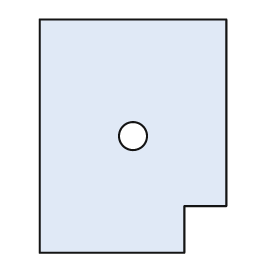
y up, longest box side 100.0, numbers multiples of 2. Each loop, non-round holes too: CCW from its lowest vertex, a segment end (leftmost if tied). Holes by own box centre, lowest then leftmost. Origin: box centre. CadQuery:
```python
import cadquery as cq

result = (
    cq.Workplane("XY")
    .moveTo(-40.0, -50.0)
    .lineTo(22.0, -50.0)
    .lineTo(22.0, -30.0)
    .lineTo(40.0, -30.0)
    .lineTo(40.0, 50.0)
    .lineTo(-40.0, 50.0)
    .close()
    .moveTo(0.0, 0.0)
    .circle(6.0)
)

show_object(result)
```